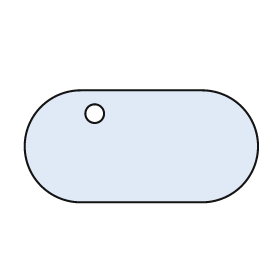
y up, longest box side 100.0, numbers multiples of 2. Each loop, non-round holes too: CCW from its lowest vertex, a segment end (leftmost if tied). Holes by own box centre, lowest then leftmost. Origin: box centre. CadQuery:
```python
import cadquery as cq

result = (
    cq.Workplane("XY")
    .moveTo(-26.0, -24.0)
    .lineTo(26.0, -24.0)
    .threePointArc((50.0, 0.0), (26.0, 24.0))
    .lineTo(-26.0, 24.0)
    .threePointArc((-50.0, 0.0), (-26.0, -24.0))
    .close()
    .moveTo(-20.0, 14.0)
    .circle(4.0)
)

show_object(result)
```